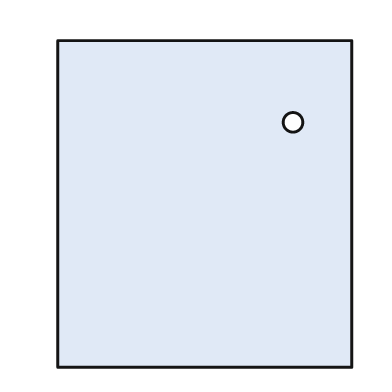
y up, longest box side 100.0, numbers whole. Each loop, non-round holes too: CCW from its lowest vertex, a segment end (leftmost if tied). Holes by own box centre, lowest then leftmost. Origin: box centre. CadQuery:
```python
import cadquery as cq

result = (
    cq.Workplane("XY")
    .moveTo(-45.0, -50.0)
    .lineTo(45.0, -50.0)
    .lineTo(45.0, 50.0)
    .lineTo(-45.0, 50.0)
    .close()
    .moveTo(27.0, 25.0)
    .circle(3.0)
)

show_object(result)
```